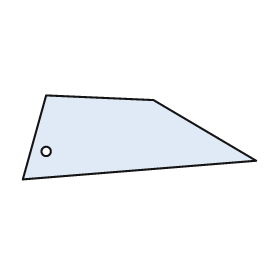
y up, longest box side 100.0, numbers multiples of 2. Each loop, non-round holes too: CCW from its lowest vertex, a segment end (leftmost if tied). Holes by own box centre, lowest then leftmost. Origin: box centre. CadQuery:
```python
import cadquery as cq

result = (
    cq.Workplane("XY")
    .moveTo(-50.0, -18.0)
    .lineTo(50.0, -10.0)
    .lineTo(6.0, 16.0)
    .lineTo(-40.0, 18.0)
    .close()
    .moveTo(-40.0, -6.0)
    .circle(2.0)
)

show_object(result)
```